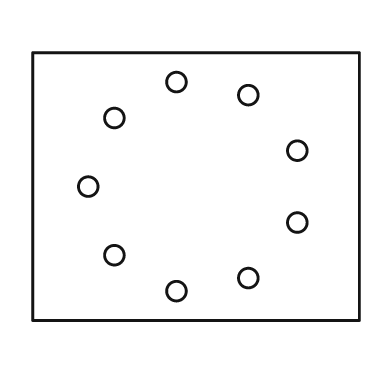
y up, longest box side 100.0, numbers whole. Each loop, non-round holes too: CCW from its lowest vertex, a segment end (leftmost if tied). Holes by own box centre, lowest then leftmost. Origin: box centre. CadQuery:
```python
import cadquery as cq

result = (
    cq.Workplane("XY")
    .moveTo(-50.0, -41.0)
    .lineTo(50.0, -41.0)
    .lineTo(50.0, 41.0)
    .lineTo(-50.0, 41.0)
    .close()
    .moveTo(-6.0, -32.0)
    .circle(3.0)
    .moveTo(16.0, -28.0)
    .circle(3.0)
    .moveTo(-25.0, -21.0)
    .circle(3.0)
    .moveTo(31.0, -11.0)
    .circle(3.0)
    .moveTo(-33.0, 0.0)
    .circle(3.0)
    .moveTo(31.0, 11.0)
    .circle(3.0)
    .moveTo(-25.0, 21.0)
    .circle(3.0)
    .moveTo(16.0, 28.0)
    .circle(3.0)
    .moveTo(-6.0, 32.0)
    .circle(3.0)
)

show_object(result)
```